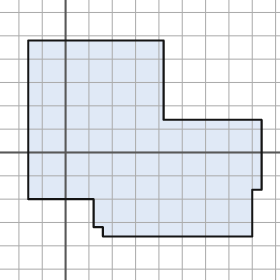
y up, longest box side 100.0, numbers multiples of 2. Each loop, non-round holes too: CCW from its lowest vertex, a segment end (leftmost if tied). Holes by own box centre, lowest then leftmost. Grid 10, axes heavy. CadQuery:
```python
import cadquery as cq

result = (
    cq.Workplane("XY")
    .moveTo(16.0, -36.0)
    .lineTo(80.0, -36.0)
    .lineTo(80.0, -16.0)
    .lineTo(84.0, -16.0)
    .lineTo(84.0, 14.0)
    .lineTo(42.0, 14.0)
    .lineTo(42.0, 48.0)
    .lineTo(-16.0, 48.0)
    .lineTo(-16.0, -20.0)
    .lineTo(12.0, -20.0)
    .lineTo(12.0, -32.0)
    .lineTo(16.0, -32.0)
    .close()
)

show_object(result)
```